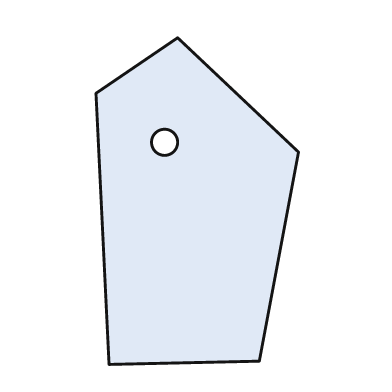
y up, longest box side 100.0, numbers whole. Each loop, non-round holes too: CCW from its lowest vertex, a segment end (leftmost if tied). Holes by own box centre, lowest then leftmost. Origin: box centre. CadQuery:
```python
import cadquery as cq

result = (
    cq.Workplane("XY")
    .moveTo(-27.0, -50.0)
    .lineTo(19.0, -49.0)
    .lineTo(31.0, 15.0)
    .lineTo(-6.0, 50.0)
    .lineTo(-31.0, 33.0)
    .close()
    .moveTo(-10.0, 18.0)
    .circle(4.0)
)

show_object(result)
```